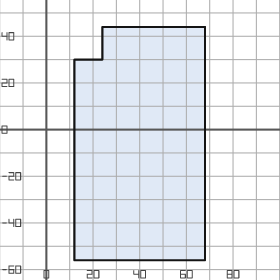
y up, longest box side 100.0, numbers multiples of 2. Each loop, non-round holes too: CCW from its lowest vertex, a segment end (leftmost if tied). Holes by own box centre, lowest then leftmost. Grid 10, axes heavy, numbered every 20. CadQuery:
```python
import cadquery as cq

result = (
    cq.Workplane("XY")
    .moveTo(12.0, -56.0)
    .lineTo(68.0, -56.0)
    .lineTo(68.0, 44.0)
    .lineTo(24.0, 44.0)
    .lineTo(24.0, 30.0)
    .lineTo(12.0, 30.0)
    .close()
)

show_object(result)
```